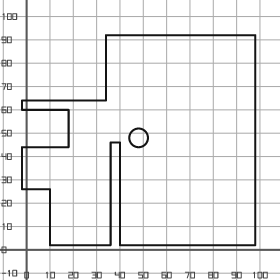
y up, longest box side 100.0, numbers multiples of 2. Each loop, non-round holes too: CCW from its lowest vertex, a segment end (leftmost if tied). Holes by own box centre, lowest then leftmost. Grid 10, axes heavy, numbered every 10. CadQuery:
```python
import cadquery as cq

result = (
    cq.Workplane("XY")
    .moveTo(10.0, 2.0)
    .lineTo(36.0, 2.0)
    .lineTo(36.0, 46.0)
    .lineTo(40.0, 46.0)
    .lineTo(40.0, 2.0)
    .lineTo(98.0, 2.0)
    .lineTo(98.0, 92.0)
    .lineTo(34.0, 92.0)
    .lineTo(34.0, 64.0)
    .lineTo(-2.0, 64.0)
    .lineTo(-2.0, 60.0)
    .lineTo(18.0, 60.0)
    .lineTo(18.0, 44.0)
    .lineTo(-2.0, 44.0)
    .lineTo(-2.0, 26.0)
    .lineTo(10.0, 26.0)
    .close()
    .moveTo(48.0, 48.0)
    .circle(4.0)
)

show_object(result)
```